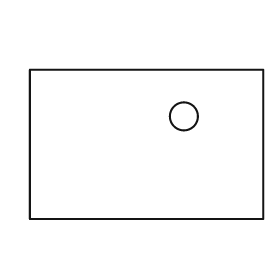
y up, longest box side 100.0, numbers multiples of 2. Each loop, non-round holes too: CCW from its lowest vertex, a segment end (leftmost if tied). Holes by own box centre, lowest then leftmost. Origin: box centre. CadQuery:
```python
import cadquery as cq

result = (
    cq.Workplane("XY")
    .moveTo(-50.0, -32.0)
    .lineTo(50.0, -32.0)
    .lineTo(50.0, 32.0)
    .lineTo(-50.0, 32.0)
    .close()
    .moveTo(16.0, 12.0)
    .circle(6.0)
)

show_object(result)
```